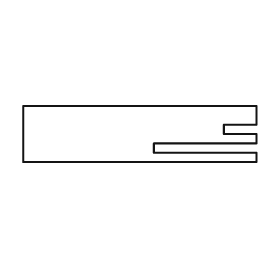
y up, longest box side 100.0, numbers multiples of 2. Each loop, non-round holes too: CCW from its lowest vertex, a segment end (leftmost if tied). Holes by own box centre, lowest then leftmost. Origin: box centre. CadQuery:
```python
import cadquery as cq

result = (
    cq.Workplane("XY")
    .moveTo(-50.0, -12.0)
    .lineTo(50.0, -12.0)
    .lineTo(50.0, -8.0)
    .lineTo(6.0, -8.0)
    .lineTo(6.0, -4.0)
    .lineTo(50.0, -4.0)
    .lineTo(50.0, 0.0)
    .lineTo(36.0, 0.0)
    .lineTo(36.0, 4.0)
    .lineTo(50.0, 4.0)
    .lineTo(50.0, 12.0)
    .lineTo(-50.0, 12.0)
    .close()
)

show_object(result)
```